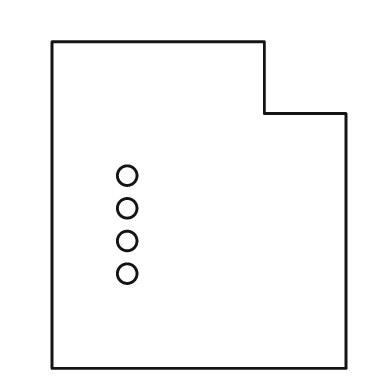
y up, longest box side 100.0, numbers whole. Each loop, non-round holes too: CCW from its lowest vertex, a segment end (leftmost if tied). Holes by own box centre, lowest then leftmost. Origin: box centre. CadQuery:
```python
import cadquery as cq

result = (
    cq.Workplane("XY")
    .moveTo(-45.0, -50.0)
    .lineTo(45.0, -50.0)
    .lineTo(45.0, 28.0)
    .lineTo(20.0, 28.0)
    .lineTo(20.0, 50.0)
    .lineTo(-45.0, 50.0)
    .close()
    .moveTo(-22.0, -21.0)
    .circle(3.0)
    .moveTo(-22.0, -11.0)
    .circle(3.0)
    .moveTo(-22.0, -1.0)
    .circle(3.0)
    .moveTo(-22.0, 9.0)
    .circle(3.0)
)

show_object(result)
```